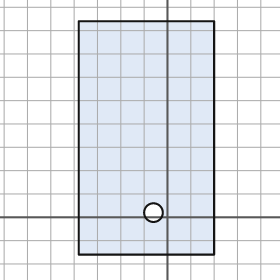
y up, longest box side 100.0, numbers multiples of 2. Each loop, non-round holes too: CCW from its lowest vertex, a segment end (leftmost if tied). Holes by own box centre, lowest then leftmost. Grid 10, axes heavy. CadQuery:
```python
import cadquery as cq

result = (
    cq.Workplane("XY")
    .moveTo(-38.0, -16.0)
    .lineTo(20.0, -16.0)
    .lineTo(20.0, 84.0)
    .lineTo(-38.0, 84.0)
    .close()
    .moveTo(-6.0, 2.0)
    .circle(4.0)
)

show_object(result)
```